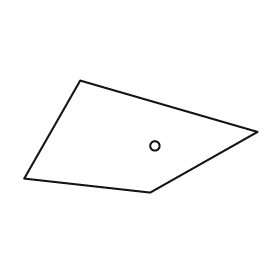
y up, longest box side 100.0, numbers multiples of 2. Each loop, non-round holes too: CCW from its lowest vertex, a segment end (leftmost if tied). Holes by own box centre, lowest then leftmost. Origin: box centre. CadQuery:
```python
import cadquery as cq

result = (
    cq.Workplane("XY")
    .moveTo(4.0, -24.0)
    .lineTo(50.0, 2.0)
    .lineTo(-26.0, 24.0)
    .lineTo(-50.0, -18.0)
    .close()
    .moveTo(6.0, -4.0)
    .circle(2.0)
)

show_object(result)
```